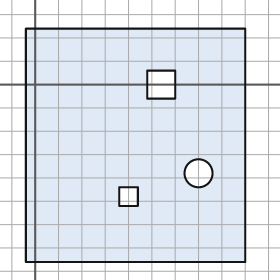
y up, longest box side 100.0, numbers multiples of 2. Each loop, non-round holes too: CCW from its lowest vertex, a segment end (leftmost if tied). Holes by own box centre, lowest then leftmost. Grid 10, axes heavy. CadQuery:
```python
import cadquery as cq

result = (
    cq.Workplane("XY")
    .moveTo(-4.0, -76.0)
    .lineTo(90.0, -76.0)
    .lineTo(90.0, 24.0)
    .lineTo(-4.0, 24.0)
    .close()
    .moveTo(36.0, -52.0)
    .lineTo(44.0, -52.0)
    .lineTo(44.0, -44.0)
    .lineTo(36.0, -44.0)
    .close()
    .moveTo(70.0, -38.0)
    .circle(6.0)
    .moveTo(48.0, -6.0)
    .lineTo(60.0, -6.0)
    .lineTo(60.0, 6.0)
    .lineTo(48.0, 6.0)
    .close()
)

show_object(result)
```